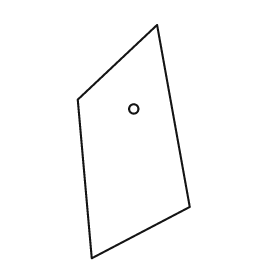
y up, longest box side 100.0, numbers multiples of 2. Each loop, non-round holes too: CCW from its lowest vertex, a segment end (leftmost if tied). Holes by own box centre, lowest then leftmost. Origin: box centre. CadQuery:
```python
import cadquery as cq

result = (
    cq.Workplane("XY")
    .moveTo(-18.0, -50.0)
    .lineTo(24.0, -28.0)
    .lineTo(10.0, 50.0)
    .lineTo(-24.0, 18.0)
    .close()
    .moveTo(0.0, 14.0)
    .circle(2.0)
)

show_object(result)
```